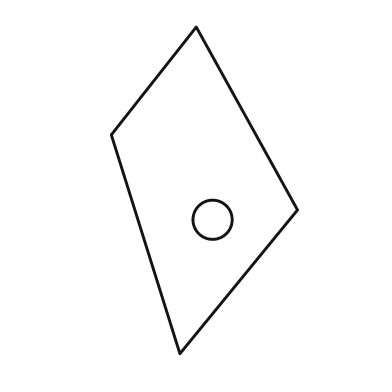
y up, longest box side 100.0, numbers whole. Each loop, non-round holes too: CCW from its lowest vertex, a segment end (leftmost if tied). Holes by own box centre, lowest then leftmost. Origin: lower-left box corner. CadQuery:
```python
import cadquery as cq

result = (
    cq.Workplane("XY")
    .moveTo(21.0, 0.0)
    .lineTo(57.0, 44.0)
    .lineTo(26.0, 100.0)
    .lineTo(0.0, 67.0)
    .close()
    .moveTo(31.0, 41.0)
    .circle(6.0)
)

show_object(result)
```